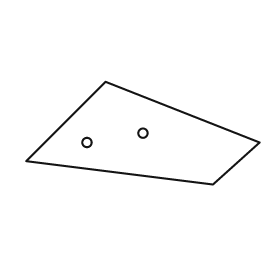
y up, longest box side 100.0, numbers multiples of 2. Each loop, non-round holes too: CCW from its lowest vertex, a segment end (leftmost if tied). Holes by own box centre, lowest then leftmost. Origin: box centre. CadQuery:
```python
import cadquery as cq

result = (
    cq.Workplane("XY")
    .moveTo(30.0, -22.0)
    .lineTo(50.0, -4.0)
    .lineTo(-16.0, 22.0)
    .lineTo(-50.0, -12.0)
    .close()
    .moveTo(-24.0, -4.0)
    .circle(2.0)
    .moveTo(0.0, 0.0)
    .circle(2.0)
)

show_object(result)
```